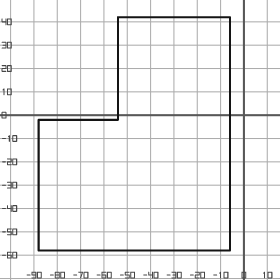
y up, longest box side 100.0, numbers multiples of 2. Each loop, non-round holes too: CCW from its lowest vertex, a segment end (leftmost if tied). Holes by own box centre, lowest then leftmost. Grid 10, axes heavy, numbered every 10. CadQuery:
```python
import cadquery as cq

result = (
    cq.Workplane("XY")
    .moveTo(-88.0, -58.0)
    .lineTo(-6.0, -58.0)
    .lineTo(-6.0, 42.0)
    .lineTo(-54.0, 42.0)
    .lineTo(-54.0, -2.0)
    .lineTo(-88.0, -2.0)
    .close()
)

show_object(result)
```